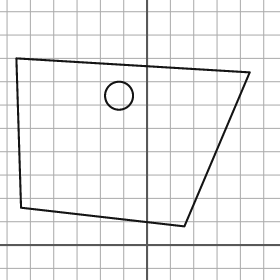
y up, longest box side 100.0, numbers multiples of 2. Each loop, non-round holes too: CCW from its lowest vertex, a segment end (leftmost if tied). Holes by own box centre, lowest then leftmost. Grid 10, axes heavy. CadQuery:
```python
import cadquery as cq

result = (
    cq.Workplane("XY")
    .moveTo(16.0, 8.0)
    .lineTo(44.0, 74.0)
    .lineTo(-56.0, 80.0)
    .lineTo(-54.0, 16.0)
    .close()
    .moveTo(-12.0, 64.0)
    .circle(6.0)
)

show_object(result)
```